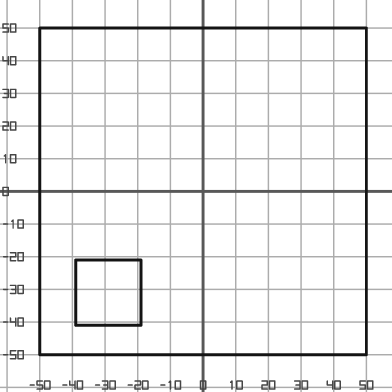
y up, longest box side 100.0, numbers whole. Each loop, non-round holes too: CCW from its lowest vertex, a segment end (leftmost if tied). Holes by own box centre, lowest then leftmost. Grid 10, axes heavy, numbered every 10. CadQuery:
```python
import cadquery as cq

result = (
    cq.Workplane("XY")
    .moveTo(-50.0, -50.0)
    .lineTo(50.0, -50.0)
    .lineTo(50.0, 50.0)
    .lineTo(-50.0, 50.0)
    .close()
    .moveTo(-39.0, -41.0)
    .lineTo(-19.0, -41.0)
    .lineTo(-19.0, -21.0)
    .lineTo(-39.0, -21.0)
    .close()
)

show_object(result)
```